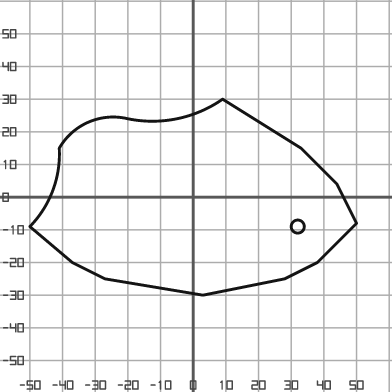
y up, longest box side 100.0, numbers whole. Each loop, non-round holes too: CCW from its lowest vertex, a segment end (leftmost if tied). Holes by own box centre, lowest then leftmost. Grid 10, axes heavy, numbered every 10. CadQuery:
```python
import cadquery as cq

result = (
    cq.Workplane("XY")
    .moveTo(3.0, -30.0)
    .lineTo(28.0, -25.0)
    .lineTo(38.0, -20.0)
    .lineTo(50.0, -8.0)
    .lineTo(44.0, 4.0)
    .lineTo(33.0, 15.0)
    .lineTo(9.0, 30.0)
    .threePointArc((-5.0, 24.0), (-20.0, 24.0))
    .threePointArc((-32.0, 23.0), (-41.0, 15.0))
    .threePointArc((-43.0, 2.0), (-50.0, -9.0))
    .lineTo(-37.0, -20.0)
    .lineTo(-27.0, -25.0)
    .close()
    .moveTo(32.0, -9.0)
    .circle(2.0)
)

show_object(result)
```